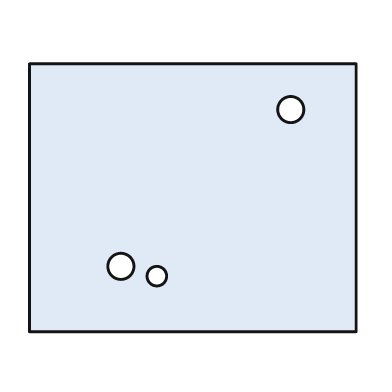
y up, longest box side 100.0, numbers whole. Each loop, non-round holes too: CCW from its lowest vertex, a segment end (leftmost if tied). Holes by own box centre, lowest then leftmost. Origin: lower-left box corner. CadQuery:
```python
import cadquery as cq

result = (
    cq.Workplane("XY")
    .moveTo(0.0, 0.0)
    .lineTo(100.0, 0.0)
    .lineTo(100.0, 82.0)
    .lineTo(0.0, 82.0)
    .close()
    .moveTo(39.0, 17.0)
    .circle(3.0)
    .moveTo(28.0, 20.0)
    .circle(4.0)
    .moveTo(80.0, 68.0)
    .circle(4.0)
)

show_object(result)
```